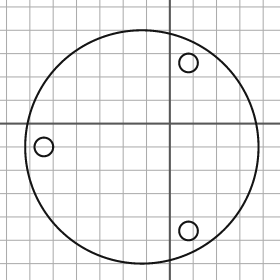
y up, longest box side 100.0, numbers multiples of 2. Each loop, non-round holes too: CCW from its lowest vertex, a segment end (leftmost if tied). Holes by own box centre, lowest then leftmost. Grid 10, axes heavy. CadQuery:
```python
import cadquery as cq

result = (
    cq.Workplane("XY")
    .moveTo(-12.0, -10.0)
    .circle(50.0)
    .moveTo(8.0, -46.0)
    .circle(4.0)
    .moveTo(-54.0, -10.0)
    .circle(4.0)
    .moveTo(8.0, 26.0)
    .circle(4.0)
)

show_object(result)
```